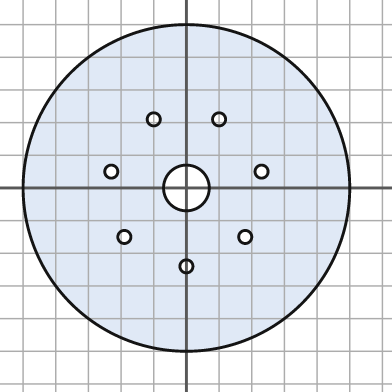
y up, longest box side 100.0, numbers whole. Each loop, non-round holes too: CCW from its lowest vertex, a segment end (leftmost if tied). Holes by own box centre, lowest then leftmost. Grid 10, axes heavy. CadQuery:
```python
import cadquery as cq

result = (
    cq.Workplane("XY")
    .moveTo(0.0, 0.0)
    .circle(50.0)
    .moveTo(0.0, -24.0)
    .circle(2.0)
    .moveTo(-19.0, -15.0)
    .circle(2.0)
    .moveTo(18.0, -15.0)
    .circle(2.0)
    .moveTo(0.0, 0.0)
    .circle(7.0)
    .moveTo(-23.0, 5.0)
    .circle(2.0)
    .moveTo(23.0, 5.0)
    .circle(2.0)
    .moveTo(-10.0, 21.0)
    .circle(2.0)
    .moveTo(10.0, 21.0)
    .circle(2.0)
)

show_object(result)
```